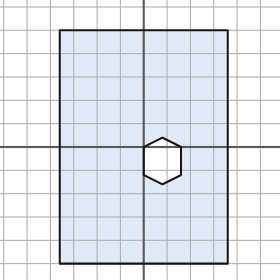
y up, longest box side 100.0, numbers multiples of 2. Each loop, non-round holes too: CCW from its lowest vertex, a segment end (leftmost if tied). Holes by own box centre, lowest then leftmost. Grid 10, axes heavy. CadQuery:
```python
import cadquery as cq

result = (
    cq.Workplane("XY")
    .moveTo(-36.0, -50.0)
    .lineTo(36.0, -50.0)
    .lineTo(36.0, 50.0)
    .lineTo(-36.0, 50.0)
    .close()
    .moveTo(8.0, -16.0)
    .lineTo(16.0, -12.0)
    .lineTo(16.0, 0.0)
    .lineTo(8.0, 4.0)
    .lineTo(0.0, 0.0)
    .lineTo(0.0, -12.0)
    .close()
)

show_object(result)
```